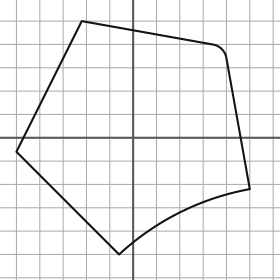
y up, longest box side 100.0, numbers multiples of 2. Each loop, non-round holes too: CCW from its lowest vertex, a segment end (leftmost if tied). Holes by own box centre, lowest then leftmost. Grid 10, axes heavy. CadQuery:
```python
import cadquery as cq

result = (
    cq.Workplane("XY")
    .moveTo(-6.0, -50.0)
    .threePointArc((20.0, -32.0), (50.0, -22.0))
    .lineTo(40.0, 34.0)
    .threePointArc((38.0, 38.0), (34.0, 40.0))
    .lineTo(-22.0, 50.0)
    .lineTo(-50.0, -6.0)
    .close()
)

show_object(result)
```